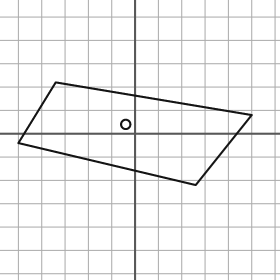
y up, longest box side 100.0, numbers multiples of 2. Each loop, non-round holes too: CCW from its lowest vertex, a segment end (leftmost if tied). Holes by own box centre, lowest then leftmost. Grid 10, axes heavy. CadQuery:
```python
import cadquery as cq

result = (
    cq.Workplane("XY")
    .moveTo(26.0, -22.0)
    .lineTo(50.0, 8.0)
    .lineTo(-34.0, 22.0)
    .lineTo(-50.0, -4.0)
    .close()
    .moveTo(-4.0, 4.0)
    .circle(2.0)
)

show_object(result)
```